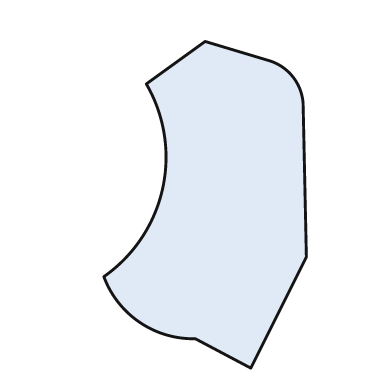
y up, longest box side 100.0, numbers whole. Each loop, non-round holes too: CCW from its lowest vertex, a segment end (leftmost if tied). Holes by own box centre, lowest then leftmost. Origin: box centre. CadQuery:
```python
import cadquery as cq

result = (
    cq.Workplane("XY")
    .moveTo(14.0, -50.0)
    .lineTo(31.0, -16.0)
    .lineTo(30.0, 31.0)
    .threePointArc((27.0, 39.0), (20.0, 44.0))
    .lineTo(0.0, 50.0)
    .lineTo(-18.0, 37.0)
    .threePointArc((-13.0, 5.0), (-31.0, -22.0))
    .threePointArc((-20.0, -36.0), (-3.0, -41.0))
    .close()
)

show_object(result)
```